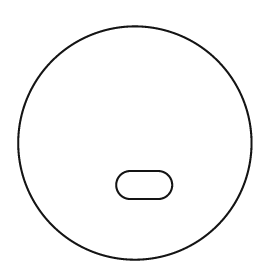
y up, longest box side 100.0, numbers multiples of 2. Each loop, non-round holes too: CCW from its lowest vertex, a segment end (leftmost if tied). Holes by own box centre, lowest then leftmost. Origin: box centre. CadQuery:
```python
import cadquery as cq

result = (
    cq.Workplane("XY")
    .moveTo(0.0, 0.0)
    .circle(50.0)
    .moveTo(-2.0, -24.0)
    .lineTo(10.0, -24.0)
    .threePointArc((16.0, -18.0), (10.0, -12.0))
    .lineTo(-2.0, -12.0)
    .threePointArc((-8.0, -18.0), (-2.0, -24.0))
    .close()
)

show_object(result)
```